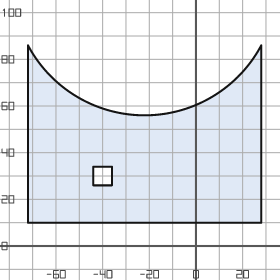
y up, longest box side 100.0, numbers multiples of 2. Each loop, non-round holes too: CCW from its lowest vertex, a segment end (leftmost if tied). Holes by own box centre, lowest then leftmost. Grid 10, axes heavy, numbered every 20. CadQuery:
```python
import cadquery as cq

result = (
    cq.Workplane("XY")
    .moveTo(-72.0, 10.0)
    .lineTo(28.0, 10.0)
    .lineTo(28.0, 86.0)
    .threePointArc((-22.0, 56.0), (-72.0, 86.0))
    .close()
    .moveTo(-44.0, 26.0)
    .lineTo(-36.0, 26.0)
    .lineTo(-36.0, 34.0)
    .lineTo(-44.0, 34.0)
    .close()
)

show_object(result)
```